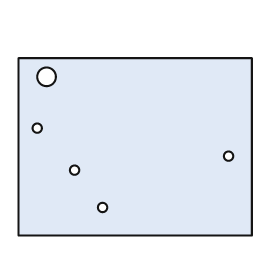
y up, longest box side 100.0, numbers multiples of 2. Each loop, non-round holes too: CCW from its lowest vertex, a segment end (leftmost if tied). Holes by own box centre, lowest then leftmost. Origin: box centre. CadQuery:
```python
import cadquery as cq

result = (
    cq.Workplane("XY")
    .moveTo(-50.0, -38.0)
    .lineTo(50.0, -38.0)
    .lineTo(50.0, 38.0)
    .lineTo(-50.0, 38.0)
    .close()
    .moveTo(-14.0, -26.0)
    .circle(2.0)
    .moveTo(-26.0, -10.0)
    .circle(2.0)
    .moveTo(40.0, -4.0)
    .circle(2.0)
    .moveTo(-42.0, 8.0)
    .circle(2.0)
    .moveTo(-38.0, 30.0)
    .circle(4.0)
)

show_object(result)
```